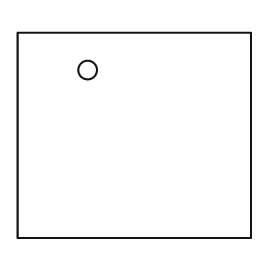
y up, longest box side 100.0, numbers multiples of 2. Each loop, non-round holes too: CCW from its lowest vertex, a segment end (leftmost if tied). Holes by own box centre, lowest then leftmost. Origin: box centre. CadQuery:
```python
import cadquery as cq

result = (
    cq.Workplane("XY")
    .moveTo(-50.0, -44.0)
    .lineTo(50.0, -44.0)
    .lineTo(50.0, 44.0)
    .lineTo(-50.0, 44.0)
    .close()
    .moveTo(-20.0, 28.0)
    .circle(4.0)
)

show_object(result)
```